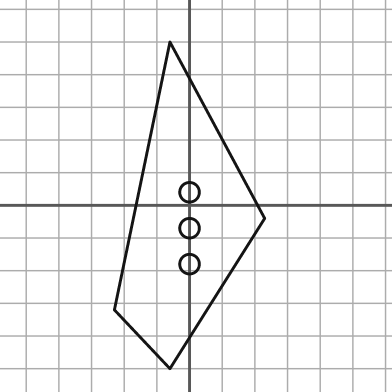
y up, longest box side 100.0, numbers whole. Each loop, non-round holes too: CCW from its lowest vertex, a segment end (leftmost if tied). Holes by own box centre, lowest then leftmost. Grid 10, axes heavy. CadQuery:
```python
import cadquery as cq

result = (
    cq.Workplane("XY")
    .moveTo(-6.0, -50.0)
    .lineTo(23.0, -4.0)
    .lineTo(-6.0, 50.0)
    .lineTo(-23.0, -32.0)
    .close()
    .moveTo(0.0, -18.0)
    .circle(3.0)
    .moveTo(0.0, -7.0)
    .circle(3.0)
    .moveTo(0.0, 4.0)
    .circle(3.0)
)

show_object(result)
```